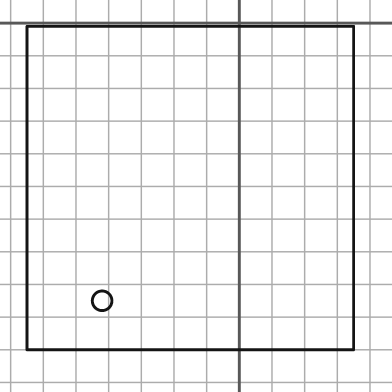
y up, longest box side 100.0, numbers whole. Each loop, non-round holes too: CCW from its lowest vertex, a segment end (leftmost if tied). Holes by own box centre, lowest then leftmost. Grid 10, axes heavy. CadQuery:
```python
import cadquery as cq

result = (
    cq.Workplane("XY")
    .moveTo(-65.0, -100.0)
    .lineTo(35.0, -100.0)
    .lineTo(35.0, -1.0)
    .lineTo(-65.0, -1.0)
    .close()
    .moveTo(-42.0, -85.0)
    .circle(3.0)
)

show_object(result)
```